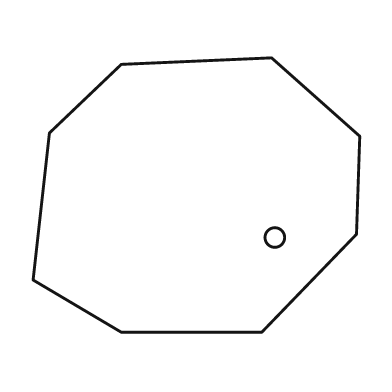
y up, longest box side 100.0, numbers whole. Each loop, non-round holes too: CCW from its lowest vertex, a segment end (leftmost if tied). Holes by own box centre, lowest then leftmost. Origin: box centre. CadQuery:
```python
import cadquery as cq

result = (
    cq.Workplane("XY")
    .moveTo(-23.0, -42.0)
    .lineTo(20.0, -42.0)
    .lineTo(49.0, -12.0)
    .lineTo(50.0, 18.0)
    .lineTo(23.0, 42.0)
    .lineTo(-23.0, 40.0)
    .lineTo(-45.0, 19.0)
    .lineTo(-50.0, -26.0)
    .close()
    .moveTo(24.0, -13.0)
    .circle(3.0)
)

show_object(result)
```